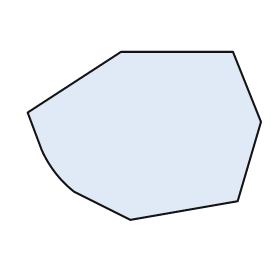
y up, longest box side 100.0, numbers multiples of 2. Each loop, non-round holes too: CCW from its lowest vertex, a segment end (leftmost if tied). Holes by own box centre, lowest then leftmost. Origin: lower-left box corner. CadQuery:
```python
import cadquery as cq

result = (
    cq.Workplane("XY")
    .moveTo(44.0, 0.0)
    .lineTo(90.0, 8.0)
    .lineTo(100.0, 42.0)
    .lineTo(88.0, 72.0)
    .lineTo(40.0, 72.0)
    .lineTo(0.0, 46.0)
    .lineTo(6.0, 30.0)
    .threePointArc((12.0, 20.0), (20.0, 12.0))
    .close()
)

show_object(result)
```